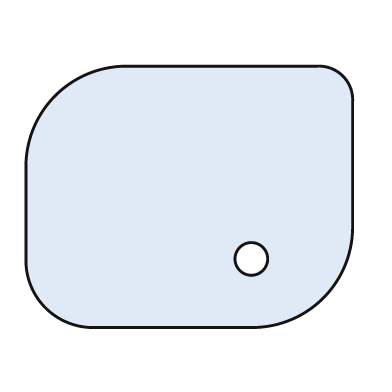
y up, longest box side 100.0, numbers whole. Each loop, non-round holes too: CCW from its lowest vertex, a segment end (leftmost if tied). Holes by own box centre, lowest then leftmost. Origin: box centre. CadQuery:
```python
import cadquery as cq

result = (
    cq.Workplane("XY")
    .moveTo(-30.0, -40.0)
    .lineTo(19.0, -40.0)
    .threePointArc((41.0, -31.0), (50.0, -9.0))
    .lineTo(50.0, 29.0)
    .threePointArc((47.0, 37.0), (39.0, 40.0))
    .lineTo(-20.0, 40.0)
    .threePointArc((-41.0, 31.0), (-50.0, 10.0))
    .lineTo(-50.0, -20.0)
    .threePointArc((-44.0, -34.0), (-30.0, -40.0))
    .close()
    .moveTo(19.0, -19.0)
    .circle(5.0)
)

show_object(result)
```